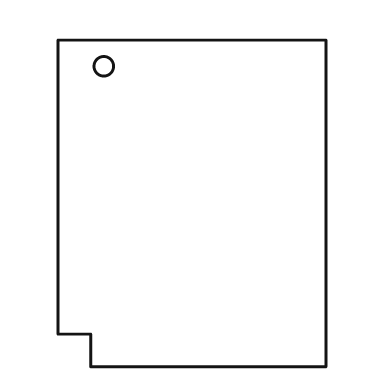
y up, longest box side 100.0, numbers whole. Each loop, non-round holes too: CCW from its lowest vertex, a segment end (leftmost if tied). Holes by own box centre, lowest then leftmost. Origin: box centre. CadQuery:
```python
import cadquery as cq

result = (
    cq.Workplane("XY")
    .moveTo(-31.0, -50.0)
    .lineTo(41.0, -50.0)
    .lineTo(41.0, 50.0)
    .lineTo(-41.0, 50.0)
    .lineTo(-41.0, -40.0)
    .lineTo(-31.0, -40.0)
    .close()
    .moveTo(-27.0, 42.0)
    .circle(3.0)
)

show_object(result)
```